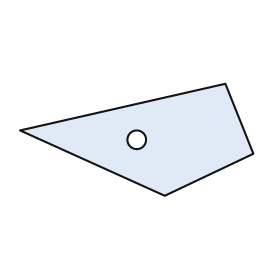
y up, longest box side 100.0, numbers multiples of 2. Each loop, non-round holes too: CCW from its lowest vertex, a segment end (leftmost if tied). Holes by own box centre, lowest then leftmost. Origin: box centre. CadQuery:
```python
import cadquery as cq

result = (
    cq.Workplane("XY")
    .moveTo(12.0, -24.0)
    .lineTo(50.0, -6.0)
    .lineTo(38.0, 24.0)
    .lineTo(-50.0, 4.0)
    .close()
    .moveTo(0.0, 0.0)
    .circle(4.0)
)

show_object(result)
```